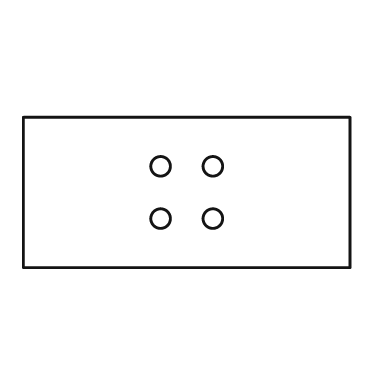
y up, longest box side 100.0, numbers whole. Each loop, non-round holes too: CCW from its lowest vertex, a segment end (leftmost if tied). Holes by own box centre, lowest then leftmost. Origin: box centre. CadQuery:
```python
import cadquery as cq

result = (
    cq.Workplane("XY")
    .moveTo(-50.0, -23.0)
    .lineTo(50.0, -23.0)
    .lineTo(50.0, 23.0)
    .lineTo(-50.0, 23.0)
    .close()
    .moveTo(-8.0, -8.0)
    .circle(3.0)
    .moveTo(8.0, -8.0)
    .circle(3.0)
    .moveTo(-8.0, 8.0)
    .circle(3.0)
    .moveTo(8.0, 8.0)
    .circle(3.0)
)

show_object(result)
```